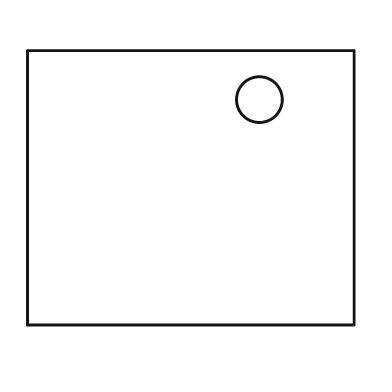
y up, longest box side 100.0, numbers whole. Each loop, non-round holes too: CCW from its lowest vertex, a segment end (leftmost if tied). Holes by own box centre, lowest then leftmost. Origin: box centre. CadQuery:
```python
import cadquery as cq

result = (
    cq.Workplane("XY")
    .moveTo(-50.0, -42.0)
    .lineTo(50.0, -42.0)
    .lineTo(50.0, 42.0)
    .lineTo(-50.0, 42.0)
    .close()
    .moveTo(21.0, 27.0)
    .circle(7.0)
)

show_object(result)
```